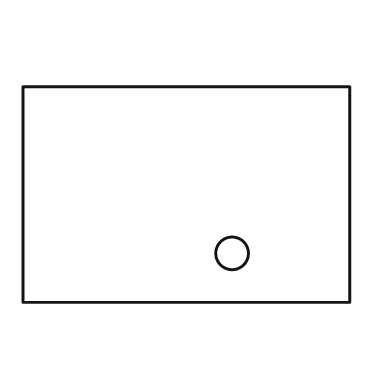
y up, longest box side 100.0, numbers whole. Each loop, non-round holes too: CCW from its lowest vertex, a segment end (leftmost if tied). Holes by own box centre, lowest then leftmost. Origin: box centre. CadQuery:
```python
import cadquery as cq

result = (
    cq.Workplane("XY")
    .moveTo(-50.0, -33.0)
    .lineTo(50.0, -33.0)
    .lineTo(50.0, 33.0)
    .lineTo(-50.0, 33.0)
    .close()
    .moveTo(14.0, -18.0)
    .circle(5.0)
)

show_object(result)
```